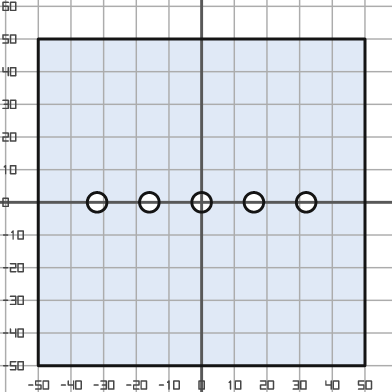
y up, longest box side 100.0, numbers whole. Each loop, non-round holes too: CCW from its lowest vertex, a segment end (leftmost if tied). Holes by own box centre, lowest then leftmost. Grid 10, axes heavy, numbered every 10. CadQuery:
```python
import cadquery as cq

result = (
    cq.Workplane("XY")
    .moveTo(-50.0, -50.0)
    .lineTo(50.0, -50.0)
    .lineTo(50.0, 50.0)
    .lineTo(-50.0, 50.0)
    .close()
    .moveTo(-32.0, 0.0)
    .circle(3.0)
    .moveTo(-16.0, 0.0)
    .circle(3.0)
    .moveTo(0.0, 0.0)
    .circle(3.0)
    .moveTo(16.0, 0.0)
    .circle(3.0)
    .moveTo(32.0, 0.0)
    .circle(3.0)
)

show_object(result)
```